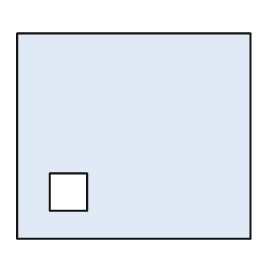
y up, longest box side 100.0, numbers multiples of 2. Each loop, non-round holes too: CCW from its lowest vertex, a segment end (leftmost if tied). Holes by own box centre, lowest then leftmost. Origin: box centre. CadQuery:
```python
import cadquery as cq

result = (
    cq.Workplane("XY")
    .moveTo(-50.0, -44.0)
    .lineTo(50.0, -44.0)
    .lineTo(50.0, 44.0)
    .lineTo(-50.0, 44.0)
    .close()
    .moveTo(-36.0, -32.0)
    .lineTo(-20.0, -32.0)
    .lineTo(-20.0, -16.0)
    .lineTo(-36.0, -16.0)
    .close()
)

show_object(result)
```